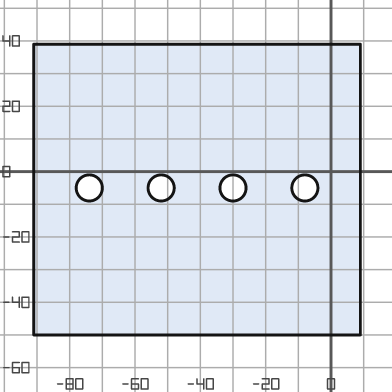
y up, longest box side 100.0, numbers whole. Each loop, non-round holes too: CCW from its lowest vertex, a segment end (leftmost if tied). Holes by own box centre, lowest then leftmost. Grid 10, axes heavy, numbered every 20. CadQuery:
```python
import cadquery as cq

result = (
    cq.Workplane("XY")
    .moveTo(-91.0, -50.0)
    .lineTo(9.0, -50.0)
    .lineTo(9.0, 39.0)
    .lineTo(-91.0, 39.0)
    .close()
    .moveTo(-74.0, -5.0)
    .circle(4.0)
    .moveTo(-52.0, -5.0)
    .circle(4.0)
    .moveTo(-30.0, -5.0)
    .circle(4.0)
    .moveTo(-8.0, -5.0)
    .circle(4.0)
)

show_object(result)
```